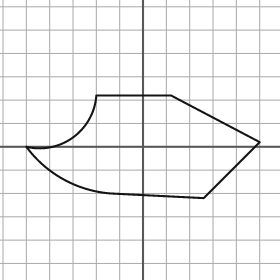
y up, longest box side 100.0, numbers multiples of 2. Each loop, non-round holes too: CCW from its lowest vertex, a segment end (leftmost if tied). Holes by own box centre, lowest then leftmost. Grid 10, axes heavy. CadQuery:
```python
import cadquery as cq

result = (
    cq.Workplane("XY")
    .moveTo(26.0, -22.0)
    .lineTo(50.0, 2.0)
    .lineTo(12.0, 22.0)
    .lineTo(-20.0, 22.0)
    .threePointArc((-30.0, 4.0), (-50.0, 0.0))
    .threePointArc((-34.0, -14.0), (-14.0, -20.0))
    .close()
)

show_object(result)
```